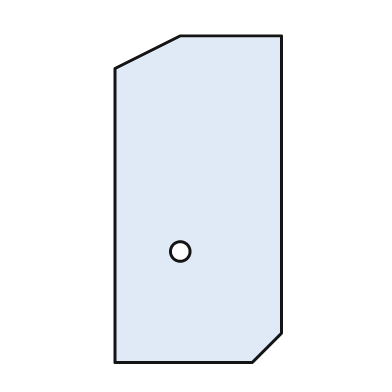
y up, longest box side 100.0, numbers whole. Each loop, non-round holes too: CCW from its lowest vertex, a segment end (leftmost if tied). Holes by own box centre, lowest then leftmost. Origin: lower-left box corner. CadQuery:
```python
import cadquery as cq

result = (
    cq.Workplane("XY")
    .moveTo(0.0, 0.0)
    .lineTo(42.0, 0.0)
    .lineTo(51.0, 9.0)
    .lineTo(51.0, 100.0)
    .lineTo(20.0, 100.0)
    .lineTo(0.0, 90.0)
    .close()
    .moveTo(20.0, 34.0)
    .circle(3.0)
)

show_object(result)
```